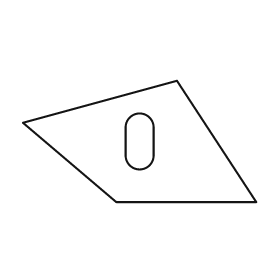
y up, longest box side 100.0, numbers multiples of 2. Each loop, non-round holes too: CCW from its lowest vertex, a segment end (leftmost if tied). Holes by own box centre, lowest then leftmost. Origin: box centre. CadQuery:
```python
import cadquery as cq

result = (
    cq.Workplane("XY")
    .moveTo(-10.0, -26.0)
    .lineTo(50.0, -26.0)
    .lineTo(16.0, 26.0)
    .lineTo(-50.0, 8.0)
    .close()
    .moveTo(-6.0, -6.0)
    .threePointArc((0.0, -12.0), (6.0, -6.0))
    .lineTo(6.0, 6.0)
    .threePointArc((0.0, 12.0), (-6.0, 6.0))
    .close()
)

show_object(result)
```